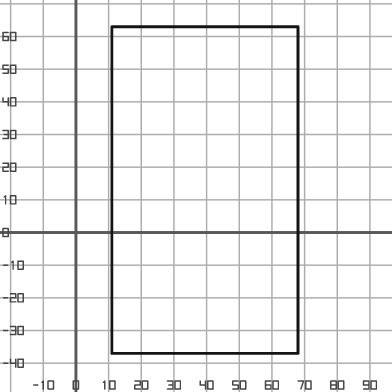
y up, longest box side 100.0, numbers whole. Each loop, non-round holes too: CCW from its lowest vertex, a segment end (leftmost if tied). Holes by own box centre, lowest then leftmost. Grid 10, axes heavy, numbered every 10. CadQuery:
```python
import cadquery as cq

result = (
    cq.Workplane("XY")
    .moveTo(11.0, -37.0)
    .lineTo(68.0, -37.0)
    .lineTo(68.0, 63.0)
    .lineTo(11.0, 63.0)
    .close()
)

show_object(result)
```